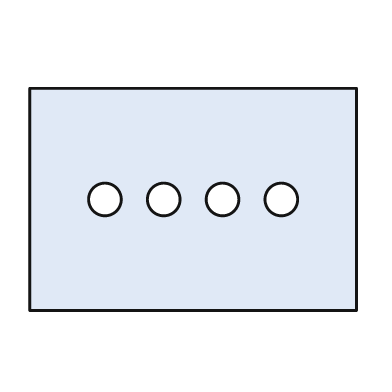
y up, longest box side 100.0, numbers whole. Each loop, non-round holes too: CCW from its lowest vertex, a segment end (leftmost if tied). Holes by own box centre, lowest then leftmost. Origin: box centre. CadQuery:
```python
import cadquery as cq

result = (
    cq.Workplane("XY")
    .moveTo(-50.0, -34.0)
    .lineTo(50.0, -34.0)
    .lineTo(50.0, 34.0)
    .lineTo(-50.0, 34.0)
    .close()
    .moveTo(-27.0, 0.0)
    .circle(5.0)
    .moveTo(-9.0, 0.0)
    .circle(5.0)
    .moveTo(9.0, 0.0)
    .circle(5.0)
    .moveTo(27.0, 0.0)
    .circle(5.0)
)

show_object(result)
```